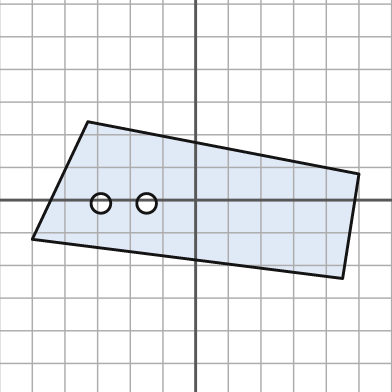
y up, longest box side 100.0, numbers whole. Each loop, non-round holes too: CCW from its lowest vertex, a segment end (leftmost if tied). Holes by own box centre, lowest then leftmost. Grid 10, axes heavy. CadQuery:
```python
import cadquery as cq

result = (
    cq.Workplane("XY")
    .moveTo(45.0, -24.0)
    .lineTo(50.0, 8.0)
    .lineTo(-33.0, 24.0)
    .lineTo(-50.0, -12.0)
    .close()
    .moveTo(-29.0, -1.0)
    .circle(3.0)
    .moveTo(-15.0, -1.0)
    .circle(3.0)
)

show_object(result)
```